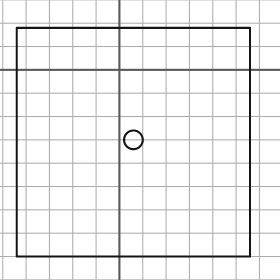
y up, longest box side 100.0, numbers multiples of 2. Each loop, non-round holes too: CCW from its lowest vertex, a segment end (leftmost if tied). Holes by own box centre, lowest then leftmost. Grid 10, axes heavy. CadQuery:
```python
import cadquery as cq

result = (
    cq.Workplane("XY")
    .moveTo(-44.0, -80.0)
    .lineTo(56.0, -80.0)
    .lineTo(56.0, 18.0)
    .lineTo(-44.0, 18.0)
    .close()
    .moveTo(6.0, -30.0)
    .circle(4.0)
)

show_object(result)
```